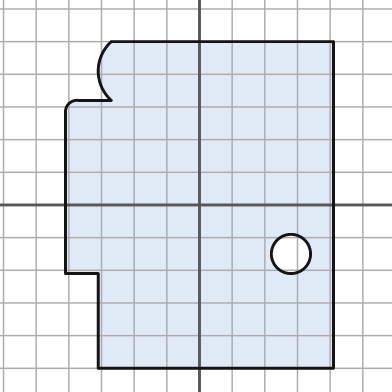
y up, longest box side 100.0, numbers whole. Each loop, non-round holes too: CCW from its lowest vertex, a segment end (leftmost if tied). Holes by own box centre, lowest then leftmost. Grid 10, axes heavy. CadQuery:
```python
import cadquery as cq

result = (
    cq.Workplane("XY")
    .moveTo(-31.0, -50.0)
    .lineTo(41.0, -50.0)
    .lineTo(41.0, 50.0)
    .lineTo(-27.0, 50.0)
    .threePointArc((-31.0, 41.0), (-27.0, 32.0))
    .lineTo(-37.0, 32.0)
    .threePointArc((-40.0, 31.0), (-41.0, 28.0))
    .lineTo(-41.0, -21.0)
    .lineTo(-31.0, -21.0)
    .close()
    .moveTo(28.0, -15.0)
    .circle(6.0)
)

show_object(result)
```